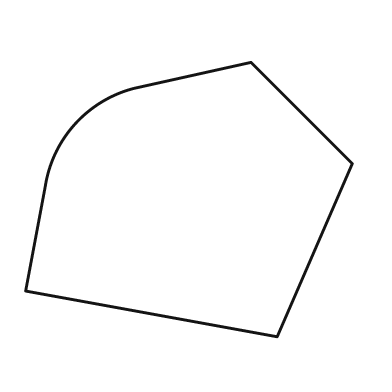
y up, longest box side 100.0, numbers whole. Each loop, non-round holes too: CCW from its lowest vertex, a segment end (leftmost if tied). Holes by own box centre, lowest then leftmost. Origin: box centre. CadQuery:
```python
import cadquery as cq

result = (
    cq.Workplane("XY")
    .moveTo(27.0, -42.0)
    .lineTo(50.0, 11.0)
    .lineTo(19.0, 42.0)
    .lineTo(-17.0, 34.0)
    .threePointArc((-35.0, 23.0), (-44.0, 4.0))
    .lineTo(-50.0, -28.0)
    .close()
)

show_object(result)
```